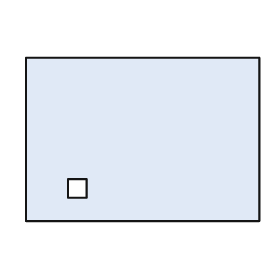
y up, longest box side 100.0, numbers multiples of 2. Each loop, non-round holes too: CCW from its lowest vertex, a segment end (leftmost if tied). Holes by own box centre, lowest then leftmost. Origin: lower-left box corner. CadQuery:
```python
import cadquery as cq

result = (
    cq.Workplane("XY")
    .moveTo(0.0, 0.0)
    .lineTo(100.0, 0.0)
    .lineTo(100.0, 70.0)
    .lineTo(0.0, 70.0)
    .close()
    .moveTo(18.0, 10.0)
    .lineTo(26.0, 10.0)
    .lineTo(26.0, 18.0)
    .lineTo(18.0, 18.0)
    .close()
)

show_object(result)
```